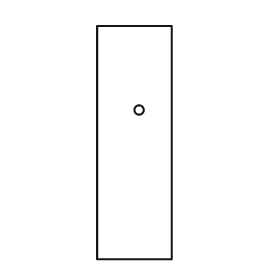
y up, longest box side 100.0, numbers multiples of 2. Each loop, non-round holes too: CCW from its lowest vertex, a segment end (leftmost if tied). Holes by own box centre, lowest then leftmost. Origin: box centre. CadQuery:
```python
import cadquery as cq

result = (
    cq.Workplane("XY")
    .moveTo(-16.0, -50.0)
    .lineTo(16.0, -50.0)
    .lineTo(16.0, 50.0)
    .lineTo(-16.0, 50.0)
    .close()
    .moveTo(2.0, 14.0)
    .circle(2.0)
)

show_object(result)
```